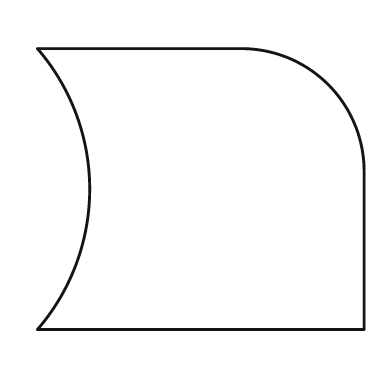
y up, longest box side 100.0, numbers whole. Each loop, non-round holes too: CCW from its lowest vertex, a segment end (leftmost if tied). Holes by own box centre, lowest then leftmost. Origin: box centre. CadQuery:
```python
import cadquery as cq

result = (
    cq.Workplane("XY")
    .moveTo(-50.0, -43.0)
    .lineTo(50.0, -43.0)
    .lineTo(50.0, 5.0)
    .threePointArc((39.0, 32.0), (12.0, 43.0))
    .lineTo(-50.0, 43.0)
    .threePointArc((-34.0, 0.0), (-50.0, -43.0))
    .close()
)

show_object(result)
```